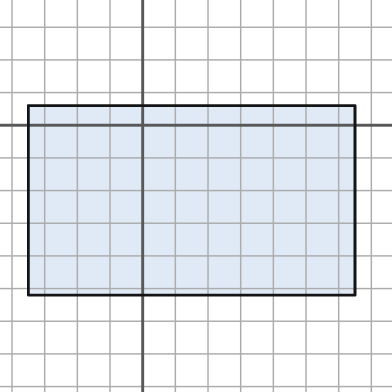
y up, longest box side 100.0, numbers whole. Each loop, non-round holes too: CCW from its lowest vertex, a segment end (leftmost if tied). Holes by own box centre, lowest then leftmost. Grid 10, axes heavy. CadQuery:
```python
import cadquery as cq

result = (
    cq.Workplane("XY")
    .moveTo(-35.0, -52.0)
    .lineTo(65.0, -52.0)
    .lineTo(65.0, 6.0)
    .lineTo(-35.0, 6.0)
    .close()
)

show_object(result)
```